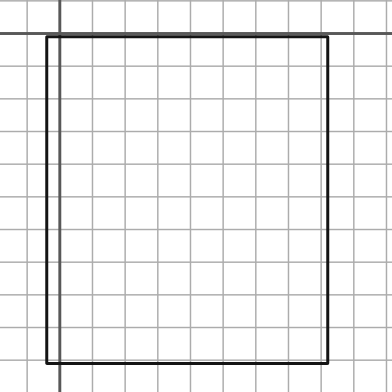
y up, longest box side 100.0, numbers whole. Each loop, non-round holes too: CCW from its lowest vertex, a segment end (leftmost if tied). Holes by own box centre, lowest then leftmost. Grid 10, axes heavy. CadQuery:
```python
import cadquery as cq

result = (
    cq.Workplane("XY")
    .moveTo(-4.0, -101.0)
    .lineTo(82.0, -101.0)
    .lineTo(82.0, -1.0)
    .lineTo(-4.0, -1.0)
    .close()
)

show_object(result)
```